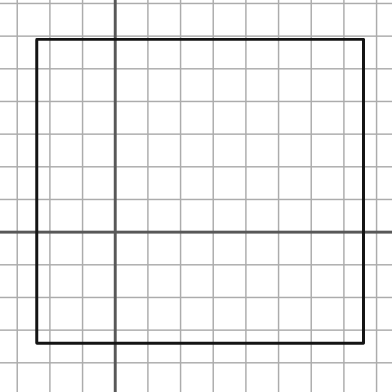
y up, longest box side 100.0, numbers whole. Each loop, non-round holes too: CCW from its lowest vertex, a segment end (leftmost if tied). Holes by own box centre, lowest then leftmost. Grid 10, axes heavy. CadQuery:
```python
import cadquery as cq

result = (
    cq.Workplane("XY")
    .moveTo(-24.0, -34.0)
    .lineTo(76.0, -34.0)
    .lineTo(76.0, 59.0)
    .lineTo(-24.0, 59.0)
    .close()
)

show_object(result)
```